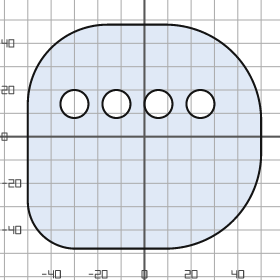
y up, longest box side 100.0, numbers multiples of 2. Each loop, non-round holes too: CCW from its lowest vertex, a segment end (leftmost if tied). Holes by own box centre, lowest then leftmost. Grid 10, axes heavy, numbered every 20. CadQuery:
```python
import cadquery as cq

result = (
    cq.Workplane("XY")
    .moveTo(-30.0, -48.0)
    .lineTo(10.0, -48.0)
    .threePointArc((38.0, -36.0), (50.0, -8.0))
    .lineTo(50.0, 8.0)
    .threePointArc((38.0, 36.0), (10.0, 48.0))
    .lineTo(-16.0, 48.0)
    .threePointArc((-40.0, 38.0), (-50.0, 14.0))
    .lineTo(-50.0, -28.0)
    .threePointArc((-44.0, -42.0), (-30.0, -48.0))
    .close()
    .moveTo(-30.0, 14.0)
    .circle(6.0)
    .moveTo(-12.0, 14.0)
    .circle(6.0)
    .moveTo(6.0, 14.0)
    .circle(6.0)
    .moveTo(24.0, 14.0)
    .circle(6.0)
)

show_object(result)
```